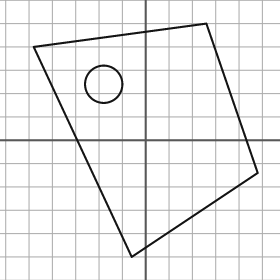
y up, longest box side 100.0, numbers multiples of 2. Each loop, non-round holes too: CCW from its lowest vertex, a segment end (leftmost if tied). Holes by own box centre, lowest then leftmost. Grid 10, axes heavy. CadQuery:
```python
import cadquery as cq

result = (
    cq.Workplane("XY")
    .moveTo(-6.0, -50.0)
    .lineTo(48.0, -14.0)
    .lineTo(26.0, 50.0)
    .lineTo(-48.0, 40.0)
    .close()
    .moveTo(-18.0, 24.0)
    .circle(8.0)
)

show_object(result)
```